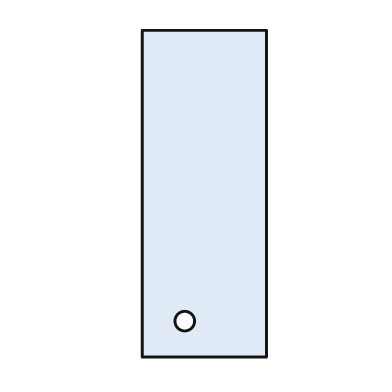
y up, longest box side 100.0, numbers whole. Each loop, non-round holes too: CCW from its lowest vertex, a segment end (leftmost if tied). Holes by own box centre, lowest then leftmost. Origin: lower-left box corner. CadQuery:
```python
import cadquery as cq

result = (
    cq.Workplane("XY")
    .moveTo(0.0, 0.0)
    .lineTo(38.0, 0.0)
    .lineTo(38.0, 100.0)
    .lineTo(0.0, 100.0)
    .close()
    .moveTo(13.0, 11.0)
    .circle(3.0)
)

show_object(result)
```